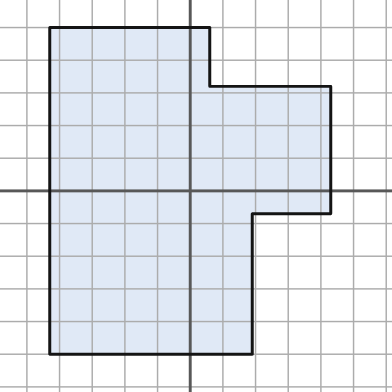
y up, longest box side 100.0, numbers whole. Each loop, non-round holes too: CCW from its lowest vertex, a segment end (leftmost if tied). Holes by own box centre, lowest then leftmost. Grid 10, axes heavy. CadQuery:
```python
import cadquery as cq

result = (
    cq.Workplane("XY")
    .moveTo(-43.0, -50.0)
    .lineTo(19.0, -50.0)
    .lineTo(19.0, -7.0)
    .lineTo(43.0, -7.0)
    .lineTo(43.0, 32.0)
    .lineTo(6.0, 32.0)
    .lineTo(6.0, 50.0)
    .lineTo(-43.0, 50.0)
    .close()
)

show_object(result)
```